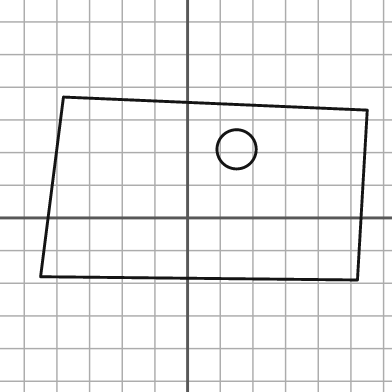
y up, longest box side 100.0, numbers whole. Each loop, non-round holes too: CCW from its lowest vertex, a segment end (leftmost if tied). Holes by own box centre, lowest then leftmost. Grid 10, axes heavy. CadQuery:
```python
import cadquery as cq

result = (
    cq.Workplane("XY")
    .moveTo(52.0, -19.0)
    .lineTo(55.0, 33.0)
    .lineTo(-38.0, 37.0)
    .lineTo(-45.0, -18.0)
    .close()
    .moveTo(15.0, 21.0)
    .circle(6.0)
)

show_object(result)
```